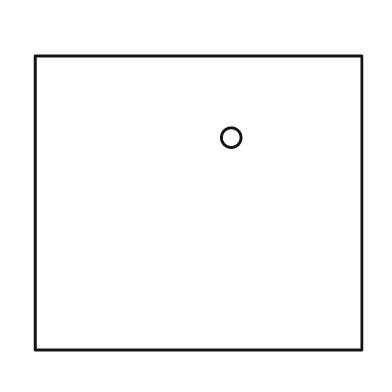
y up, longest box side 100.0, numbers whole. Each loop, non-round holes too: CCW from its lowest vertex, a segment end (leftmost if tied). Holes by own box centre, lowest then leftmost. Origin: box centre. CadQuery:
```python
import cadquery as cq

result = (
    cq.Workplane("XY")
    .moveTo(-50.0, -45.0)
    .lineTo(50.0, -45.0)
    .lineTo(50.0, 45.0)
    .lineTo(-50.0, 45.0)
    .close()
    .moveTo(10.0, 20.0)
    .circle(3.0)
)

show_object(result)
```